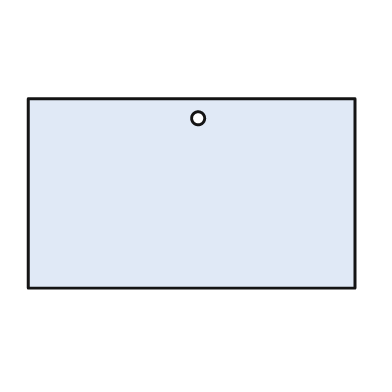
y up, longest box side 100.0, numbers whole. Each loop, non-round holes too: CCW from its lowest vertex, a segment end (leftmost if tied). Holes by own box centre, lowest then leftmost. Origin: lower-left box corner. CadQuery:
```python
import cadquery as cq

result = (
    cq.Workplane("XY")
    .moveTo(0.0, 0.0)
    .lineTo(100.0, 0.0)
    .lineTo(100.0, 58.0)
    .lineTo(0.0, 58.0)
    .close()
    .moveTo(52.0, 52.0)
    .circle(2.0)
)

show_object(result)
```